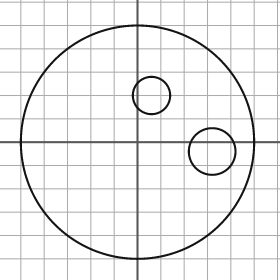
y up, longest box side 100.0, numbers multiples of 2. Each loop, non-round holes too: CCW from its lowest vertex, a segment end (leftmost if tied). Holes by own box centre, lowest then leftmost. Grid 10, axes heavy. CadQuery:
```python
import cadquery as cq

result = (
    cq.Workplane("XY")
    .moveTo(0.0, 0.0)
    .circle(50.0)
    .moveTo(32.0, -4.0)
    .circle(10.0)
    .moveTo(6.0, 20.0)
    .circle(8.0)
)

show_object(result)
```